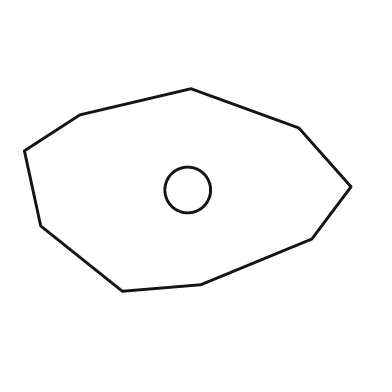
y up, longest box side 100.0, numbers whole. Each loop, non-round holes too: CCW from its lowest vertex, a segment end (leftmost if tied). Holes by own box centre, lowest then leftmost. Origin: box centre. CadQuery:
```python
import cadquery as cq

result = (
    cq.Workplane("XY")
    .moveTo(-20.0, -31.0)
    .lineTo(4.0, -29.0)
    .lineTo(38.0, -15.0)
    .lineTo(50.0, 1.0)
    .lineTo(34.0, 19.0)
    .lineTo(1.0, 31.0)
    .lineTo(-33.0, 23.0)
    .lineTo(-50.0, 12.0)
    .lineTo(-45.0, -11.0)
    .close()
    .moveTo(0.0, 0.0)
    .circle(7.0)
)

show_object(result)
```